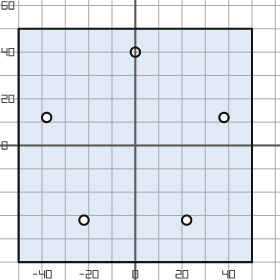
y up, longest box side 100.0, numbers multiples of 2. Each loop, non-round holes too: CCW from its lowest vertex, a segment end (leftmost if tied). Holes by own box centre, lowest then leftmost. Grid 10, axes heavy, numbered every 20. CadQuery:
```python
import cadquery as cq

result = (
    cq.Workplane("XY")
    .moveTo(-50.0, -50.0)
    .lineTo(50.0, -50.0)
    .lineTo(50.0, 50.0)
    .lineTo(-50.0, 50.0)
    .close()
    .moveTo(-22.0, -32.0)
    .circle(2.0)
    .moveTo(22.0, -32.0)
    .circle(2.0)
    .moveTo(-38.0, 12.0)
    .circle(2.0)
    .moveTo(38.0, 12.0)
    .circle(2.0)
    .moveTo(0.0, 40.0)
    .circle(2.0)
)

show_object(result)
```